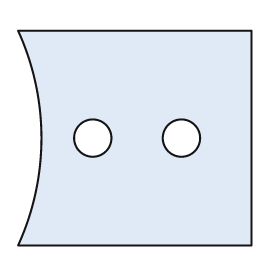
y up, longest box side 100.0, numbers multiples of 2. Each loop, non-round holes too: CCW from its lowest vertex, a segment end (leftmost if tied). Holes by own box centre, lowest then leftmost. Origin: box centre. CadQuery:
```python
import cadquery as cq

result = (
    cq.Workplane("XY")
    .moveTo(-50.0, -46.0)
    .lineTo(50.0, -46.0)
    .lineTo(50.0, 46.0)
    .lineTo(-50.0, 46.0)
    .threePointArc((-40.0, 0.0), (-50.0, -46.0))
    .close()
    .moveTo(-18.0, 0.0)
    .circle(8.0)
    .moveTo(20.0, 0.0)
    .circle(8.0)
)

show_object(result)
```